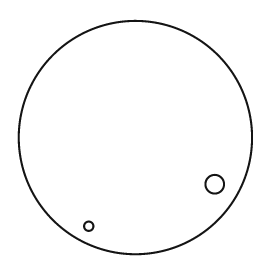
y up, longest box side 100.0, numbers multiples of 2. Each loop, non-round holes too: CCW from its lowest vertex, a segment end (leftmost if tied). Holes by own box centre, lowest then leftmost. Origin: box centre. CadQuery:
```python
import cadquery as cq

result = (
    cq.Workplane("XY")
    .moveTo(0.0, 0.0)
    .circle(50.0)
    .moveTo(-20.0, -38.0)
    .circle(2.0)
    .moveTo(34.0, -20.0)
    .circle(4.0)
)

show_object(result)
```